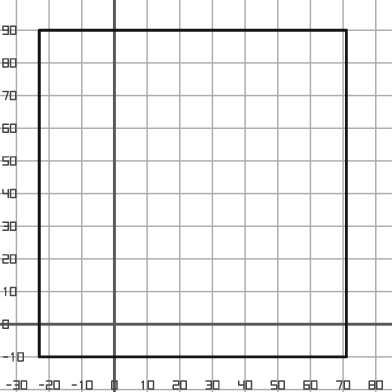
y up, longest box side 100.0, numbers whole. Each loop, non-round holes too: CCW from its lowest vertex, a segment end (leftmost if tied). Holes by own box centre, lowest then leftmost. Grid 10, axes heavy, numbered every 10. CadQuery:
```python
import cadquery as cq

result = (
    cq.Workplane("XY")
    .moveTo(-23.0, -10.0)
    .lineTo(71.0, -10.0)
    .lineTo(71.0, 90.0)
    .lineTo(-23.0, 90.0)
    .close()
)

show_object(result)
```